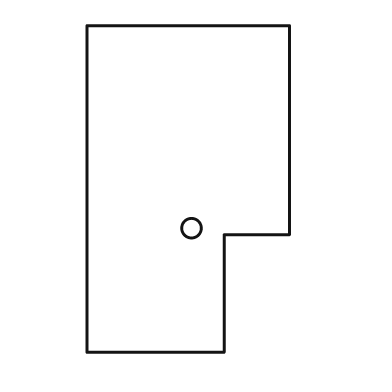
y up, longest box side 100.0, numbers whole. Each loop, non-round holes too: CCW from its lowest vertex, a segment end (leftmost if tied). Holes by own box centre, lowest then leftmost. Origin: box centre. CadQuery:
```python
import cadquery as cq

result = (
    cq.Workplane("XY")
    .moveTo(-31.0, -50.0)
    .lineTo(11.0, -50.0)
    .lineTo(11.0, -14.0)
    .lineTo(31.0, -14.0)
    .lineTo(31.0, 50.0)
    .lineTo(-31.0, 50.0)
    .close()
    .moveTo(1.0, -12.0)
    .circle(3.0)
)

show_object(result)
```